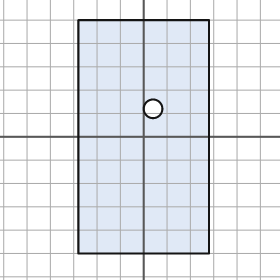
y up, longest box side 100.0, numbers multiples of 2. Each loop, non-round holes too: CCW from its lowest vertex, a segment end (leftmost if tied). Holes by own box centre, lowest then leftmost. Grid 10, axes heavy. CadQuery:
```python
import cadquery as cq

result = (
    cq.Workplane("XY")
    .moveTo(-28.0, -50.0)
    .lineTo(28.0, -50.0)
    .lineTo(28.0, 50.0)
    .lineTo(-28.0, 50.0)
    .close()
    .moveTo(4.0, 12.0)
    .circle(4.0)
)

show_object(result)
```